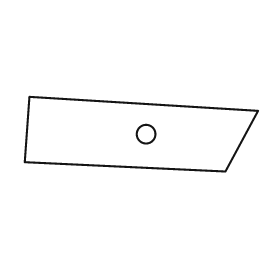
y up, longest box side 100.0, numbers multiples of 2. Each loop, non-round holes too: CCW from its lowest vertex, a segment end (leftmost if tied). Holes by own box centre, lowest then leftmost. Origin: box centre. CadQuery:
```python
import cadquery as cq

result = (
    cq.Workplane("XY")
    .moveTo(36.0, -16.0)
    .lineTo(50.0, 10.0)
    .lineTo(-48.0, 16.0)
    .lineTo(-50.0, -12.0)
    .close()
    .moveTo(2.0, 0.0)
    .circle(4.0)
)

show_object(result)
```